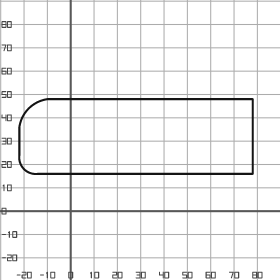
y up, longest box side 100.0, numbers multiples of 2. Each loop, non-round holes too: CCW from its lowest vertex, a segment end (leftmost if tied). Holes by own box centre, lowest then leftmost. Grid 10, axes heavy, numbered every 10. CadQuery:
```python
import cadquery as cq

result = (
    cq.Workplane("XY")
    .moveTo(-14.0, 16.0)
    .lineTo(78.0, 16.0)
    .lineTo(78.0, 48.0)
    .lineTo(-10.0, 48.0)
    .threePointArc((-18.0, 44.0), (-22.0, 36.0))
    .lineTo(-22.0, 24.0)
    .threePointArc((-20.0, 18.0), (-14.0, 16.0))
    .close()
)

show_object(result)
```